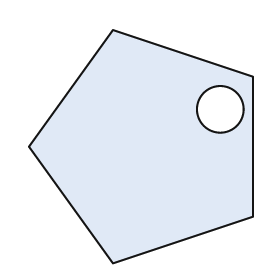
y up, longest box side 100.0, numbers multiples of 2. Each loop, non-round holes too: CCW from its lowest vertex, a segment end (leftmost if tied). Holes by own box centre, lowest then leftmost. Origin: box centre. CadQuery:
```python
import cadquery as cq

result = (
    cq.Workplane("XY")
    .moveTo(-12.0, -50.0)
    .lineTo(48.0, -30.0)
    .lineTo(48.0, 30.0)
    .lineTo(-12.0, 50.0)
    .lineTo(-48.0, 0.0)
    .close()
    .moveTo(34.0, 16.0)
    .circle(10.0)
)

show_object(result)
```